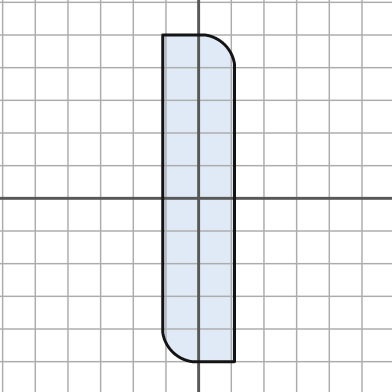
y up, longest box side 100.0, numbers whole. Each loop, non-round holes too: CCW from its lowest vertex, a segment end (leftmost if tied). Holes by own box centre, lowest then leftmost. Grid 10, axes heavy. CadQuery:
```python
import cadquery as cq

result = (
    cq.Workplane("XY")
    .moveTo(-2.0, -50.0)
    .lineTo(11.0, -50.0)
    .lineTo(11.0, 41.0)
    .threePointArc((8.0, 47.0), (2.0, 50.0))
    .lineTo(-11.0, 50.0)
    .lineTo(-11.0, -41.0)
    .threePointArc((-8.0, -47.0), (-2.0, -50.0))
    .close()
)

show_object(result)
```